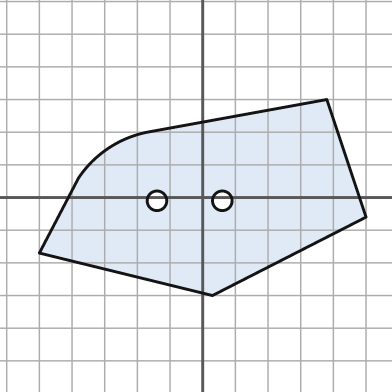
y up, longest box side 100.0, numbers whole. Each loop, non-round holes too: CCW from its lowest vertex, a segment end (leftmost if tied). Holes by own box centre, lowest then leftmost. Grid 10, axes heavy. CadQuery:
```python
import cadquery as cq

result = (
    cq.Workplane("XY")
    .moveTo(3.0, -30.0)
    .lineTo(50.0, -6.0)
    .lineTo(38.0, 30.0)
    .lineTo(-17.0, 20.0)
    .threePointArc((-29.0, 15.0), (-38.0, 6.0))
    .lineTo(-50.0, -17.0)
    .close()
    .moveTo(-14.0, -1.0)
    .circle(3.0)
    .moveTo(6.0, -1.0)
    .circle(3.0)
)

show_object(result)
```